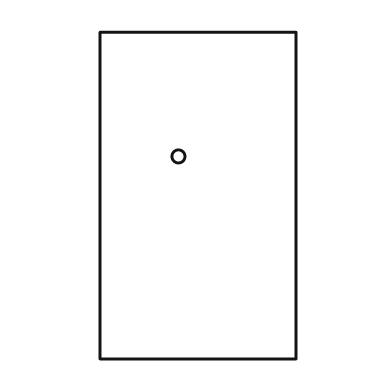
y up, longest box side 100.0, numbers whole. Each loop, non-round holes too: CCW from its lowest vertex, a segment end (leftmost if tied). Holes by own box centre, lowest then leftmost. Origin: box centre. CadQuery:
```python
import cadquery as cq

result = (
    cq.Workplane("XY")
    .moveTo(-30.0, -50.0)
    .lineTo(30.0, -50.0)
    .lineTo(30.0, 50.0)
    .lineTo(-30.0, 50.0)
    .close()
    .moveTo(-6.0, 12.0)
    .circle(2.0)
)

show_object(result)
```